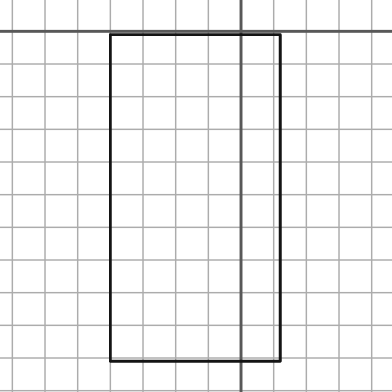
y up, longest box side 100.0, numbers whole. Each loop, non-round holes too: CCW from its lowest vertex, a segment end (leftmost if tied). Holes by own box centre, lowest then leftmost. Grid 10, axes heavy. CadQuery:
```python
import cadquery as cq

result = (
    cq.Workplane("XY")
    .moveTo(-40.0, -101.0)
    .lineTo(12.0, -101.0)
    .lineTo(12.0, -1.0)
    .lineTo(-40.0, -1.0)
    .close()
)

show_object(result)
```